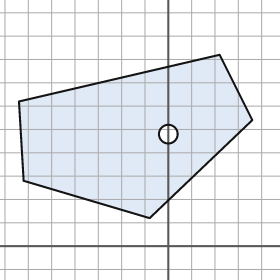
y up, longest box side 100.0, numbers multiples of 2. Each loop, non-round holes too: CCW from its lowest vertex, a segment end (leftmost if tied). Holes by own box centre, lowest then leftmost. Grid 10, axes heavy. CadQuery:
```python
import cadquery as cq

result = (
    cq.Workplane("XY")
    .moveTo(-8.0, 12.0)
    .lineTo(36.0, 54.0)
    .lineTo(22.0, 82.0)
    .lineTo(-64.0, 62.0)
    .lineTo(-62.0, 28.0)
    .close()
    .moveTo(0.0, 48.0)
    .circle(4.0)
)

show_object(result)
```